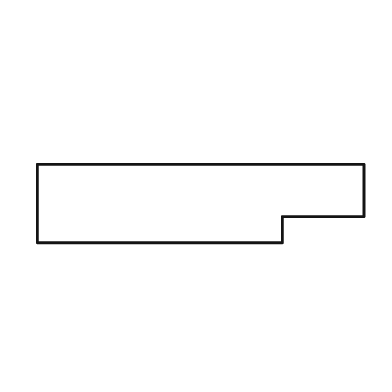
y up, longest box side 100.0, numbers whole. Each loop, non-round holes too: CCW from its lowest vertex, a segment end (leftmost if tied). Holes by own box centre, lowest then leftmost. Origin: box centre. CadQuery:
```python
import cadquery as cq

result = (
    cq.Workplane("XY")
    .moveTo(-50.0, -12.0)
    .lineTo(25.0, -12.0)
    .lineTo(25.0, -4.0)
    .lineTo(50.0, -4.0)
    .lineTo(50.0, 12.0)
    .lineTo(-50.0, 12.0)
    .close()
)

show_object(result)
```